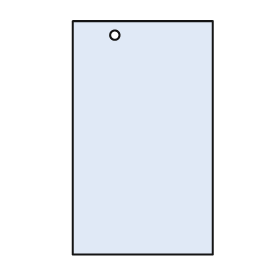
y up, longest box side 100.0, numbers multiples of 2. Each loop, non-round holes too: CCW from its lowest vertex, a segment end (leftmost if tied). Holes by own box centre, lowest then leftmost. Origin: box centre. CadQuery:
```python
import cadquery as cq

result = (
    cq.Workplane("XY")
    .moveTo(-30.0, -50.0)
    .lineTo(30.0, -50.0)
    .lineTo(30.0, 50.0)
    .lineTo(-30.0, 50.0)
    .close()
    .moveTo(-12.0, 44.0)
    .circle(2.0)
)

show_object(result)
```